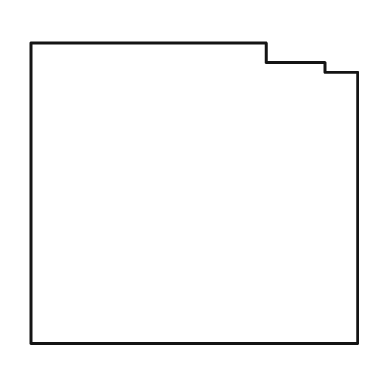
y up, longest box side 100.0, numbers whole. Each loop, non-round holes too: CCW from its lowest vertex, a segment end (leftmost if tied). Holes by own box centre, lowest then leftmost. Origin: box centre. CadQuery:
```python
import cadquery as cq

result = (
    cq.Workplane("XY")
    .moveTo(-50.0, -46.0)
    .lineTo(50.0, -46.0)
    .lineTo(50.0, 37.0)
    .lineTo(40.0, 37.0)
    .lineTo(40.0, 40.0)
    .lineTo(22.0, 40.0)
    .lineTo(22.0, 46.0)
    .lineTo(-50.0, 46.0)
    .close()
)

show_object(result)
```